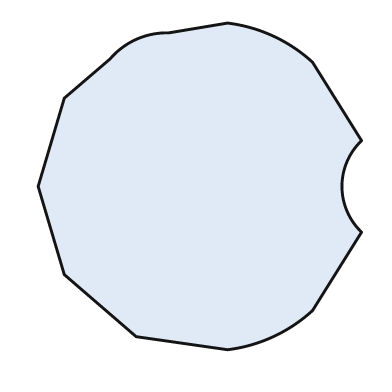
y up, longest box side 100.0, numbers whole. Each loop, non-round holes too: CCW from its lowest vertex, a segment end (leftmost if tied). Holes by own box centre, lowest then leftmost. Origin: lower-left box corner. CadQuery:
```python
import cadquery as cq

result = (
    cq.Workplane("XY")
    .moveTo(58.0, 0.0)
    .threePointArc((72.0, 4.0), (84.0, 12.0))
    .lineTo(99.0, 36.0)
    .threePointArc((93.0, 50.0), (99.0, 64.0))
    .lineTo(84.0, 88.0)
    .threePointArc((72.0, 96.0), (58.0, 100.0))
    .lineTo(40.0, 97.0)
    .threePointArc((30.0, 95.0), (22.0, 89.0))
    .lineTo(8.0, 77.0)
    .lineTo(0.0, 50.0)
    .lineTo(8.0, 23.0)
    .lineTo(30.0, 4.0)
    .close()
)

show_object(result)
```